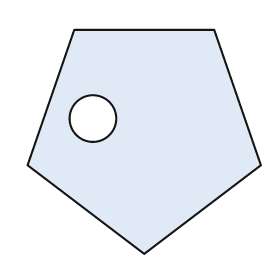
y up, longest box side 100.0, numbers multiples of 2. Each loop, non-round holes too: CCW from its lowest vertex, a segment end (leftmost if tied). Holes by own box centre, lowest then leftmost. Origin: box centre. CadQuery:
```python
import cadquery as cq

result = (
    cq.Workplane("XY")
    .moveTo(0.0, -48.0)
    .lineTo(50.0, -10.0)
    .lineTo(30.0, 48.0)
    .lineTo(-30.0, 48.0)
    .lineTo(-50.0, -10.0)
    .close()
    .moveTo(-22.0, 10.0)
    .circle(10.0)
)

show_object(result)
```